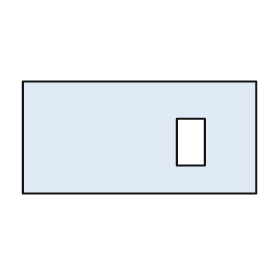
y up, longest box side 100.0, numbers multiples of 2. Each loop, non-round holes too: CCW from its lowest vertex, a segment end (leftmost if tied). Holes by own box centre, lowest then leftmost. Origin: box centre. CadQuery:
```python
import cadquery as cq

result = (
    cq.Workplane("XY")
    .moveTo(-50.0, -24.0)
    .lineTo(50.0, -24.0)
    .lineTo(50.0, 24.0)
    .lineTo(-50.0, 24.0)
    .close()
    .moveTo(16.0, -12.0)
    .lineTo(28.0, -12.0)
    .lineTo(28.0, 8.0)
    .lineTo(16.0, 8.0)
    .close()
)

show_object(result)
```